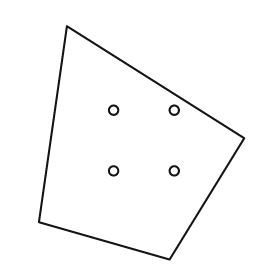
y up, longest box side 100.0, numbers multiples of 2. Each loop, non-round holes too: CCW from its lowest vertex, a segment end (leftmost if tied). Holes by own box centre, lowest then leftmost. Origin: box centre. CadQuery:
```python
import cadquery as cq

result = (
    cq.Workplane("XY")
    .moveTo(12.0, -50.0)
    .lineTo(44.0, 2.0)
    .lineTo(-32.0, 50.0)
    .lineTo(-44.0, -34.0)
    .close()
    .moveTo(-12.0, -12.0)
    .circle(2.0)
    .moveTo(14.0, -12.0)
    .circle(2.0)
    .moveTo(-12.0, 14.0)
    .circle(2.0)
    .moveTo(14.0, 14.0)
    .circle(2.0)
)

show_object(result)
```